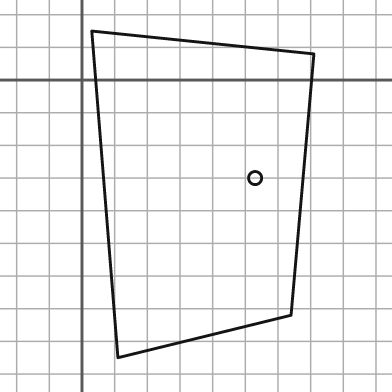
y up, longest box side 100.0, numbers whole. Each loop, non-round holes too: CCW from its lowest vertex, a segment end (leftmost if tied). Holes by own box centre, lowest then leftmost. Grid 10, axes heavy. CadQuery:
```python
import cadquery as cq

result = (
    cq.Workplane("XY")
    .moveTo(11.0, -85.0)
    .lineTo(64.0, -72.0)
    .lineTo(71.0, 8.0)
    .lineTo(3.0, 15.0)
    .close()
    .moveTo(53.0, -30.0)
    .circle(2.0)
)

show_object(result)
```